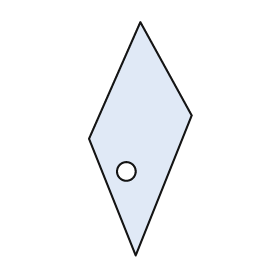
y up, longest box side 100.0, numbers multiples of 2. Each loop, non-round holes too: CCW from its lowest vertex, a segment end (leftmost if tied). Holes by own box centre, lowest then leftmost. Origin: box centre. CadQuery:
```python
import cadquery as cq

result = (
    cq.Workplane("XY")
    .moveTo(-2.0, -50.0)
    .lineTo(22.0, 10.0)
    .lineTo(0.0, 50.0)
    .lineTo(-22.0, 0.0)
    .close()
    .moveTo(-6.0, -14.0)
    .circle(4.0)
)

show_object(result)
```